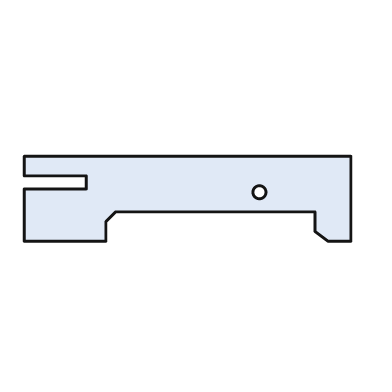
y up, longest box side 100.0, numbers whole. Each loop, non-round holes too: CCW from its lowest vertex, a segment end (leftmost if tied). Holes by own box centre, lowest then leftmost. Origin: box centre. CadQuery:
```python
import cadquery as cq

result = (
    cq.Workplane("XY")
    .moveTo(-50.0, -13.0)
    .lineTo(-25.0, -13.0)
    .lineTo(-25.0, -7.0)
    .lineTo(-22.0, -4.0)
    .lineTo(39.0, -4.0)
    .lineTo(39.0, -10.0)
    .lineTo(43.0, -13.0)
    .lineTo(50.0, -13.0)
    .lineTo(50.0, 13.0)
    .lineTo(-50.0, 13.0)
    .lineTo(-50.0, 7.0)
    .lineTo(-31.0, 7.0)
    .lineTo(-31.0, 3.0)
    .lineTo(-50.0, 3.0)
    .close()
    .moveTo(22.0, 2.0)
    .circle(2.0)
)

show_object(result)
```